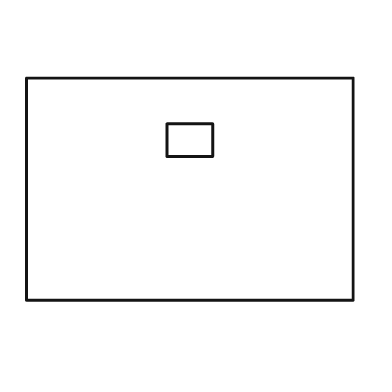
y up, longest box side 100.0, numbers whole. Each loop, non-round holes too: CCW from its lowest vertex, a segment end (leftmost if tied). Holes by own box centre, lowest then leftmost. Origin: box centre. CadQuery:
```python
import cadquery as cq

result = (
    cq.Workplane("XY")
    .moveTo(-50.0, -34.0)
    .lineTo(50.0, -34.0)
    .lineTo(50.0, 34.0)
    .lineTo(-50.0, 34.0)
    .close()
    .moveTo(-7.0, 10.0)
    .lineTo(7.0, 10.0)
    .lineTo(7.0, 20.0)
    .lineTo(-7.0, 20.0)
    .close()
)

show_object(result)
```